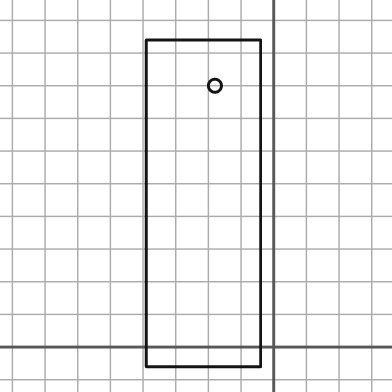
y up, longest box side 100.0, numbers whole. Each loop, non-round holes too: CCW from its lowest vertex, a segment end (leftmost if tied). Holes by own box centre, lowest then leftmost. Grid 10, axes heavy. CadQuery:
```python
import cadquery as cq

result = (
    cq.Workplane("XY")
    .moveTo(-39.0, -6.0)
    .lineTo(-4.0, -6.0)
    .lineTo(-4.0, 94.0)
    .lineTo(-39.0, 94.0)
    .close()
    .moveTo(-18.0, 80.0)
    .circle(2.0)
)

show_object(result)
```